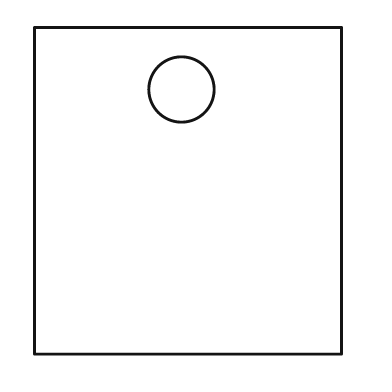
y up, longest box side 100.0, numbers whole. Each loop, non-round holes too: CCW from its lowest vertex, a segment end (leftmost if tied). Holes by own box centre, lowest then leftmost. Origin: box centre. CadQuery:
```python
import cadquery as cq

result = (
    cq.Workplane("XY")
    .moveTo(-47.0, -50.0)
    .lineTo(47.0, -50.0)
    .lineTo(47.0, 50.0)
    .lineTo(-47.0, 50.0)
    .close()
    .moveTo(-2.0, 31.0)
    .circle(10.0)
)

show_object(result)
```